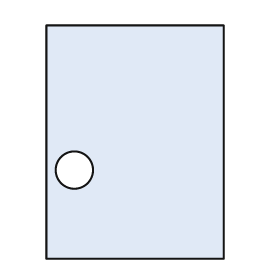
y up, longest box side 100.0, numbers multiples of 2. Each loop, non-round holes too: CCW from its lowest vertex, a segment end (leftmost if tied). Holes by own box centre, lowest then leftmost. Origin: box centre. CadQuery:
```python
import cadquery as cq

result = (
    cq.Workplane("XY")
    .moveTo(-38.0, -50.0)
    .lineTo(38.0, -50.0)
    .lineTo(38.0, 50.0)
    .lineTo(-38.0, 50.0)
    .close()
    .moveTo(-26.0, -12.0)
    .circle(8.0)
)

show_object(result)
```